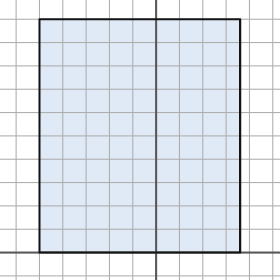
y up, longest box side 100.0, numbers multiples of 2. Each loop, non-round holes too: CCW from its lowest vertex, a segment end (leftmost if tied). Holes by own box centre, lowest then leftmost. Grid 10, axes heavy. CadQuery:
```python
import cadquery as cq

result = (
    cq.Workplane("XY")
    .moveTo(-50.0, 0.0)
    .lineTo(36.0, 0.0)
    .lineTo(36.0, 100.0)
    .lineTo(-50.0, 100.0)
    .close()
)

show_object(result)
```